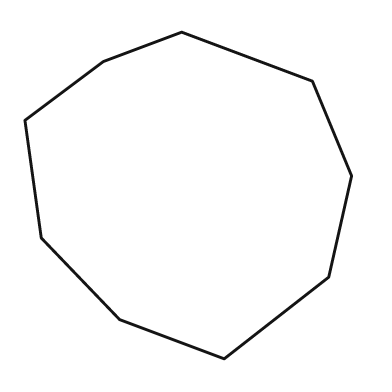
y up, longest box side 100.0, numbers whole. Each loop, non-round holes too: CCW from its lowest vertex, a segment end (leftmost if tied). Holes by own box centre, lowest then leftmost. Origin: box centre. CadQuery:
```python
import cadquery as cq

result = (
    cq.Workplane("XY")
    .moveTo(11.0, -50.0)
    .lineTo(43.0, -25.0)
    .lineTo(50.0, 6.0)
    .lineTo(38.0, 35.0)
    .lineTo(-2.0, 50.0)
    .lineTo(-26.0, 41.0)
    .lineTo(-50.0, 23.0)
    .lineTo(-45.0, -13.0)
    .lineTo(-21.0, -38.0)
    .close()
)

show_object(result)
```